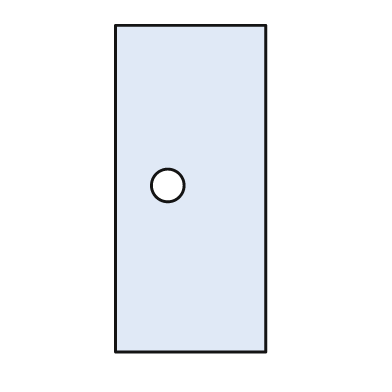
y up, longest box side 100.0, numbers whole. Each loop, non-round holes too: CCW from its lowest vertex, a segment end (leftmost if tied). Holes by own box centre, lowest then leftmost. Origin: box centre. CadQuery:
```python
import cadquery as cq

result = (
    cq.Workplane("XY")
    .moveTo(-23.0, -50.0)
    .lineTo(23.0, -50.0)
    .lineTo(23.0, 50.0)
    .lineTo(-23.0, 50.0)
    .close()
    .moveTo(-7.0, 1.0)
    .circle(5.0)
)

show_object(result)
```